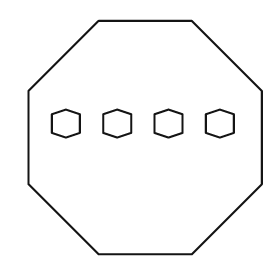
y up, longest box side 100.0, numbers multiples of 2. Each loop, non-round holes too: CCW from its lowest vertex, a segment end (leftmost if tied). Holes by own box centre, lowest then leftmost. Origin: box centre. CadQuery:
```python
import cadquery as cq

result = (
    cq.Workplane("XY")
    .moveTo(-20.0, -50.0)
    .lineTo(20.0, -50.0)
    .lineTo(50.0, -20.0)
    .lineTo(50.0, 20.0)
    .lineTo(20.0, 50.0)
    .lineTo(-20.0, 50.0)
    .lineTo(-50.0, 20.0)
    .lineTo(-50.0, -20.0)
    .close()
    .moveTo(-34.0, 0.0)
    .lineTo(-28.0, 2.0)
    .lineTo(-28.0, 10.0)
    .lineTo(-34.0, 12.0)
    .lineTo(-40.0, 10.0)
    .lineTo(-40.0, 2.0)
    .close()
    .moveTo(-12.0, 0.0)
    .lineTo(-6.0, 2.0)
    .lineTo(-6.0, 10.0)
    .lineTo(-12.0, 12.0)
    .lineTo(-18.0, 10.0)
    .lineTo(-18.0, 2.0)
    .close()
    .moveTo(10.0, 0.0)
    .lineTo(16.0, 2.0)
    .lineTo(16.0, 10.0)
    .lineTo(10.0, 12.0)
    .lineTo(4.0, 10.0)
    .lineTo(4.0, 2.0)
    .close()
    .moveTo(32.0, 0.0)
    .lineTo(38.0, 2.0)
    .lineTo(38.0, 10.0)
    .lineTo(32.0, 12.0)
    .lineTo(26.0, 10.0)
    .lineTo(26.0, 2.0)
    .close()
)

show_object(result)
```